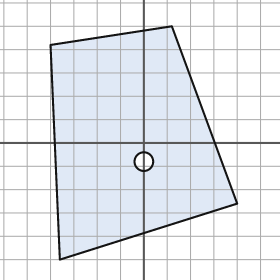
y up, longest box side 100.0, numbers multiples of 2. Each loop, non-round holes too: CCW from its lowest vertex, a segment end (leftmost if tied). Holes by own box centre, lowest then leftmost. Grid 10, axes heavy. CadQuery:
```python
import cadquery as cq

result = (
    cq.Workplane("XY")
    .moveTo(-36.0, -50.0)
    .lineTo(40.0, -26.0)
    .lineTo(12.0, 50.0)
    .lineTo(-40.0, 42.0)
    .close()
    .moveTo(0.0, -8.0)
    .circle(4.0)
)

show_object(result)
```